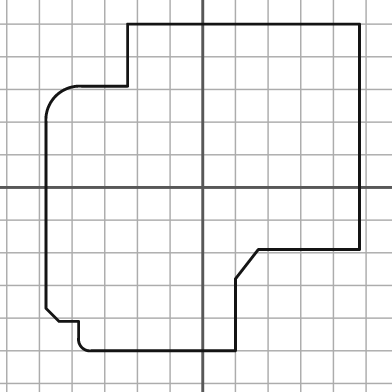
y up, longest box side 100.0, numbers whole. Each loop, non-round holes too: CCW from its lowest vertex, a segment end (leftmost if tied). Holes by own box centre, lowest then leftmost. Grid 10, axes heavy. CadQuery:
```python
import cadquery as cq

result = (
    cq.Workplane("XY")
    .moveTo(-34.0, -50.0)
    .lineTo(10.0, -50.0)
    .lineTo(10.0, -28.0)
    .lineTo(17.0, -19.0)
    .lineTo(48.0, -19.0)
    .lineTo(48.0, 50.0)
    .lineTo(-23.0, 50.0)
    .lineTo(-23.0, 31.0)
    .lineTo(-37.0, 31.0)
    .threePointArc((-45.0, 28.0), (-48.0, 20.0))
    .lineTo(-48.0, -37.0)
    .lineTo(-44.0, -41.0)
    .lineTo(-38.0, -41.0)
    .lineTo(-38.0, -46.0)
    .threePointArc((-37.0, -49.0), (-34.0, -50.0))
    .close()
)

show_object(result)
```